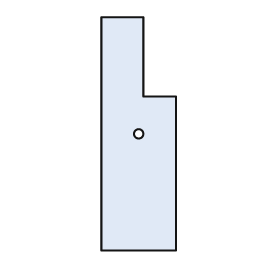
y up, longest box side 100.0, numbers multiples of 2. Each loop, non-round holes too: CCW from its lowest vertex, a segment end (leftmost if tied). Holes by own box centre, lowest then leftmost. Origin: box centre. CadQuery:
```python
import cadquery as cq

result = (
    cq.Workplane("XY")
    .moveTo(-16.0, -50.0)
    .lineTo(16.0, -50.0)
    .lineTo(16.0, 16.0)
    .lineTo(2.0, 16.0)
    .lineTo(2.0, 50.0)
    .lineTo(-16.0, 50.0)
    .close()
    .moveTo(0.0, 0.0)
    .circle(2.0)
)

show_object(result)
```